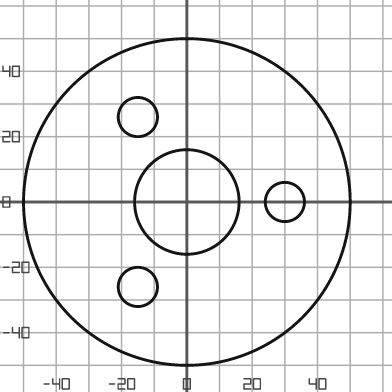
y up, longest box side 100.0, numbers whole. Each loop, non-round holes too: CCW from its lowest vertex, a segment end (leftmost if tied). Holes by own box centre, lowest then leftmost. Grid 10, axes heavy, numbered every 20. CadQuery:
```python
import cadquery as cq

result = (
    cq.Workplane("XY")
    .moveTo(0.0, 0.0)
    .circle(50.0)
    .moveTo(-15.0, -26.0)
    .circle(6.0)
    .moveTo(0.0, 0.0)
    .circle(16.0)
    .moveTo(30.0, 0.0)
    .circle(6.0)
    .moveTo(-15.0, 26.0)
    .circle(6.0)
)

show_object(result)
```